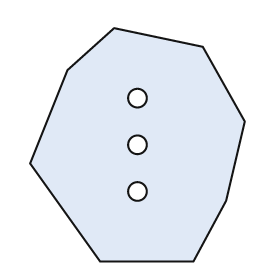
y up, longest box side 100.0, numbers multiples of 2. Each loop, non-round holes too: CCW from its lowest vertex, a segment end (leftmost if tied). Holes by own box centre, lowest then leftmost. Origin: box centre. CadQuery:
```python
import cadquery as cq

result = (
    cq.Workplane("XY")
    .moveTo(-16.0, -50.0)
    .lineTo(24.0, -50.0)
    .lineTo(38.0, -24.0)
    .lineTo(46.0, 10.0)
    .lineTo(28.0, 42.0)
    .lineTo(-10.0, 50.0)
    .lineTo(-30.0, 32.0)
    .lineTo(-46.0, -8.0)
    .close()
    .moveTo(0.0, -20.0)
    .circle(4.0)
    .moveTo(0.0, 0.0)
    .circle(4.0)
    .moveTo(0.0, 20.0)
    .circle(4.0)
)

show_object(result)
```